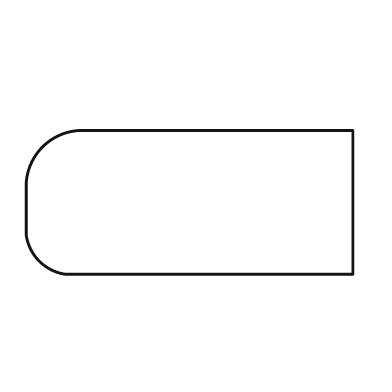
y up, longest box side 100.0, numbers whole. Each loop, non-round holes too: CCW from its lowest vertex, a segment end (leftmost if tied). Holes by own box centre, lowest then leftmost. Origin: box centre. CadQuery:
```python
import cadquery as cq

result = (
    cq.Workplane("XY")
    .moveTo(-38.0, -22.0)
    .lineTo(50.0, -22.0)
    .lineTo(50.0, 22.0)
    .lineTo(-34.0, 22.0)
    .threePointArc((-45.0, 17.0), (-50.0, 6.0))
    .lineTo(-50.0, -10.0)
    .threePointArc((-46.0, -18.0), (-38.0, -22.0))
    .close()
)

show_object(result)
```